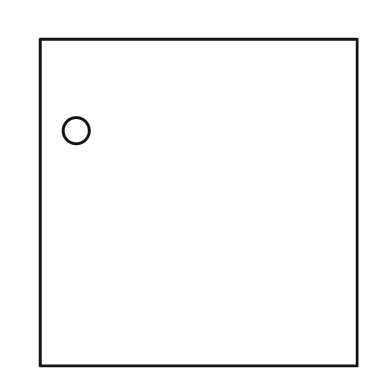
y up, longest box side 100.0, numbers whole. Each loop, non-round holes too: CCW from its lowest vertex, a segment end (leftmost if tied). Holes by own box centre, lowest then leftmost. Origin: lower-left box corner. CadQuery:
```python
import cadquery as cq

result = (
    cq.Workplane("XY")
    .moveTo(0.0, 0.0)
    .lineTo(97.0, 0.0)
    .lineTo(97.0, 100.0)
    .lineTo(0.0, 100.0)
    .close()
    .moveTo(11.0, 72.0)
    .circle(4.0)
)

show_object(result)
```